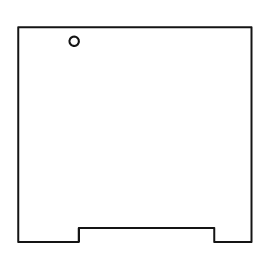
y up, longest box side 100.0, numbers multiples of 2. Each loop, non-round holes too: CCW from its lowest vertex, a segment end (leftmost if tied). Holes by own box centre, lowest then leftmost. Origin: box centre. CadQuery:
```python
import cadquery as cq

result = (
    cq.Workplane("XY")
    .moveTo(-50.0, -46.0)
    .lineTo(-24.0, -46.0)
    .lineTo(-24.0, -40.0)
    .lineTo(34.0, -40.0)
    .lineTo(34.0, -46.0)
    .lineTo(50.0, -46.0)
    .lineTo(50.0, 46.0)
    .lineTo(-50.0, 46.0)
    .close()
    .moveTo(-26.0, 40.0)
    .circle(2.0)
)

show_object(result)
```